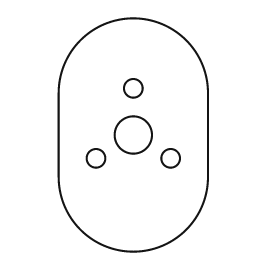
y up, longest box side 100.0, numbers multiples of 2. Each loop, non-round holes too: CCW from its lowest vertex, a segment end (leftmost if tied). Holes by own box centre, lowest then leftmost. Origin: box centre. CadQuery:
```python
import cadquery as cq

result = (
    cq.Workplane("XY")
    .moveTo(-32.0, -18.0)
    .threePointArc((0.0, -50.0), (32.0, -18.0))
    .lineTo(32.0, 18.0)
    .threePointArc((0.0, 50.0), (-32.0, 18.0))
    .close()
    .moveTo(-16.0, -10.0)
    .circle(4.0)
    .moveTo(16.0, -10.0)
    .circle(4.0)
    .moveTo(0.0, 0.0)
    .circle(8.0)
    .moveTo(0.0, 20.0)
    .circle(4.0)
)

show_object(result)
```